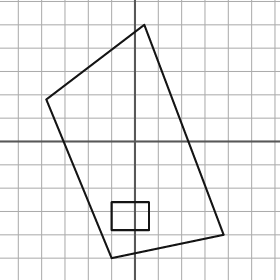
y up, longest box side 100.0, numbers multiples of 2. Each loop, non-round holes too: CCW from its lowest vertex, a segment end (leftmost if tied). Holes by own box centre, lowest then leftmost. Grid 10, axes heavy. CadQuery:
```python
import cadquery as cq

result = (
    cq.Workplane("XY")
    .moveTo(-10.0, -50.0)
    .lineTo(38.0, -40.0)
    .lineTo(4.0, 50.0)
    .lineTo(-38.0, 18.0)
    .close()
    .moveTo(-10.0, -38.0)
    .lineTo(6.0, -38.0)
    .lineTo(6.0, -26.0)
    .lineTo(-10.0, -26.0)
    .close()
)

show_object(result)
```